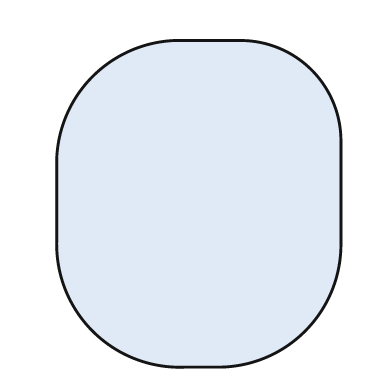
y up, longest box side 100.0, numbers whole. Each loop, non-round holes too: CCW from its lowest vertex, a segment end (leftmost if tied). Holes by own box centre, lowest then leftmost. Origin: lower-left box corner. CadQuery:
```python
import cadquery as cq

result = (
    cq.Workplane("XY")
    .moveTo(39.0, 0.0)
    .lineTo(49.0, 0.0)
    .threePointArc((76.0, 11.0), (87.0, 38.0))
    .lineTo(87.0, 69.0)
    .threePointArc((78.0, 91.0), (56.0, 100.0))
    .lineTo(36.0, 100.0)
    .threePointArc((11.0, 89.0), (0.0, 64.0))
    .lineTo(0.0, 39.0)
    .threePointArc((11.0, 11.0), (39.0, 0.0))
    .close()
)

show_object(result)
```